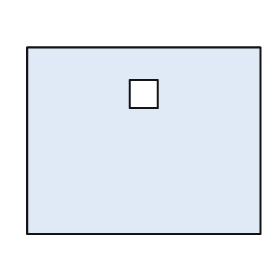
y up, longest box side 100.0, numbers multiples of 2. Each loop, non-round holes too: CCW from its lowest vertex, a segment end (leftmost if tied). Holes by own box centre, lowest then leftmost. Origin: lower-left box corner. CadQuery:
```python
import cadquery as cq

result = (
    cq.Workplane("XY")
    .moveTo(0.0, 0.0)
    .lineTo(100.0, 0.0)
    .lineTo(100.0, 80.0)
    .lineTo(0.0, 80.0)
    .close()
    .moveTo(44.0, 54.0)
    .lineTo(56.0, 54.0)
    .lineTo(56.0, 66.0)
    .lineTo(44.0, 66.0)
    .close()
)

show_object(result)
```